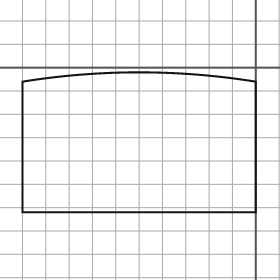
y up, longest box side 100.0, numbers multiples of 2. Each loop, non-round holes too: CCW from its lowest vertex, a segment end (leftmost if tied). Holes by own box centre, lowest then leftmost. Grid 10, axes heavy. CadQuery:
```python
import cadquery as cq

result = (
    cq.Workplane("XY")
    .moveTo(-100.0, -62.0)
    .lineTo(0.0, -62.0)
    .lineTo(0.0, -6.0)
    .threePointArc((-50.0, -2.0), (-100.0, -6.0))
    .close()
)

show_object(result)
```